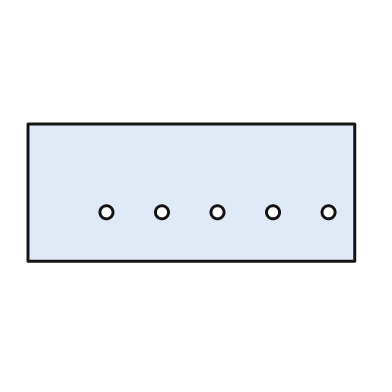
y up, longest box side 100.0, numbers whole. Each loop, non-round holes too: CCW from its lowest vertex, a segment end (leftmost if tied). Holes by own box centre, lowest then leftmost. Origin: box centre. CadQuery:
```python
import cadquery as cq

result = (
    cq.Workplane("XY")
    .moveTo(-50.0, -21.0)
    .lineTo(50.0, -21.0)
    .lineTo(50.0, 21.0)
    .lineTo(-50.0, 21.0)
    .close()
    .moveTo(-26.0, -6.0)
    .circle(2.0)
    .moveTo(-9.0, -6.0)
    .circle(2.0)
    .moveTo(8.0, -6.0)
    .circle(2.0)
    .moveTo(25.0, -6.0)
    .circle(2.0)
    .moveTo(42.0, -6.0)
    .circle(2.0)
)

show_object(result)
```